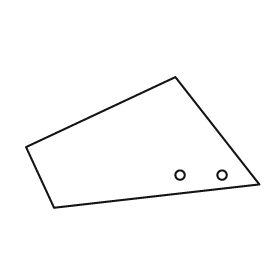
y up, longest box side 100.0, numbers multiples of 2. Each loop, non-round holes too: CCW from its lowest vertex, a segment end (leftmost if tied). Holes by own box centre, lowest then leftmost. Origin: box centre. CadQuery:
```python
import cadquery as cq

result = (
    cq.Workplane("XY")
    .moveTo(-38.0, -28.0)
    .lineTo(50.0, -18.0)
    .lineTo(14.0, 28.0)
    .lineTo(-50.0, -2.0)
    .close()
    .moveTo(16.0, -14.0)
    .circle(2.0)
    .moveTo(34.0, -14.0)
    .circle(2.0)
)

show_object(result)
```